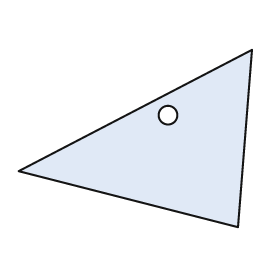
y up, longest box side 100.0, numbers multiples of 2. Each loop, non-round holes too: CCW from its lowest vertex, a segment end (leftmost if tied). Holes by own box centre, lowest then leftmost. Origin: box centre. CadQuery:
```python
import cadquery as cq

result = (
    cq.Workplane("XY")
    .moveTo(44.0, -38.0)
    .lineTo(50.0, 38.0)
    .lineTo(-50.0, -14.0)
    .close()
    .moveTo(14.0, 10.0)
    .circle(4.0)
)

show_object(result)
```